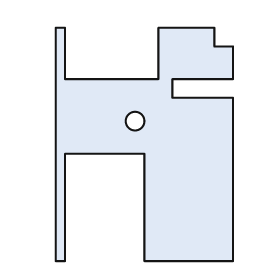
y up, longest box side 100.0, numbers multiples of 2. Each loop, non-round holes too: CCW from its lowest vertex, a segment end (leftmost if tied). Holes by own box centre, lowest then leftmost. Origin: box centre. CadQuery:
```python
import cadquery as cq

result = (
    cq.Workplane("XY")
    .moveTo(-38.0, -50.0)
    .lineTo(-34.0, -50.0)
    .lineTo(-34.0, -4.0)
    .lineTo(0.0, -4.0)
    .lineTo(0.0, -50.0)
    .lineTo(38.0, -50.0)
    .lineTo(38.0, 20.0)
    .lineTo(12.0, 20.0)
    .lineTo(12.0, 28.0)
    .lineTo(38.0, 28.0)
    .lineTo(38.0, 42.0)
    .lineTo(30.0, 42.0)
    .lineTo(30.0, 50.0)
    .lineTo(6.0, 50.0)
    .lineTo(6.0, 28.0)
    .lineTo(-34.0, 28.0)
    .lineTo(-34.0, 50.0)
    .lineTo(-38.0, 50.0)
    .close()
    .moveTo(-4.0, 10.0)
    .circle(4.0)
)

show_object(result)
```